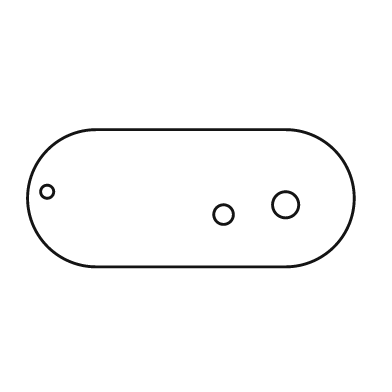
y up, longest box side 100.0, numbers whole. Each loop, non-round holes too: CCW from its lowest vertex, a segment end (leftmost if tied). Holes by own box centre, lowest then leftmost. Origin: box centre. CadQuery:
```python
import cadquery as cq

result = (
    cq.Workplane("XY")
    .moveTo(-29.0, -21.0)
    .lineTo(29.0, -21.0)
    .threePointArc((50.0, 0.0), (29.0, 21.0))
    .lineTo(-29.0, 21.0)
    .threePointArc((-50.0, 0.0), (-29.0, -21.0))
    .close()
    .moveTo(10.0, -5.0)
    .circle(3.0)
    .moveTo(29.0, -2.0)
    .circle(4.0)
    .moveTo(-44.0, 2.0)
    .circle(2.0)
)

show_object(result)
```